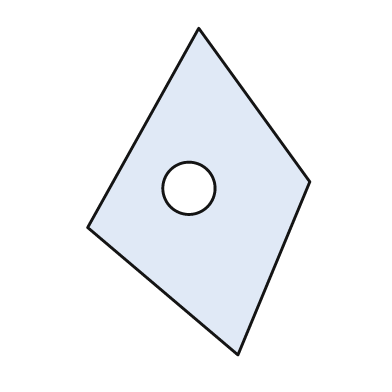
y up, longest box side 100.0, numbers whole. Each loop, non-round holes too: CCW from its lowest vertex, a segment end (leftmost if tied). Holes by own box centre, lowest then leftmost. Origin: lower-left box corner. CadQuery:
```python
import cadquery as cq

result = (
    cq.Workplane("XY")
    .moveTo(46.0, 0.0)
    .lineTo(68.0, 53.0)
    .lineTo(34.0, 100.0)
    .lineTo(0.0, 39.0)
    .close()
    .moveTo(31.0, 51.0)
    .circle(8.0)
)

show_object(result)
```